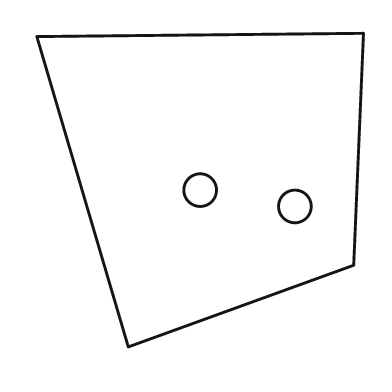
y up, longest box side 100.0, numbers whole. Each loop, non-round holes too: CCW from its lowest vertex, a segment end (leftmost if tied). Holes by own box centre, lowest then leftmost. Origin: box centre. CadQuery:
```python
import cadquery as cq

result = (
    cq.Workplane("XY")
    .moveTo(-22.0, -48.0)
    .lineTo(47.0, -23.0)
    .lineTo(50.0, 48.0)
    .lineTo(-50.0, 47.0)
    .close()
    .moveTo(29.0, -5.0)
    .circle(5.0)
    .moveTo(0.0, 0.0)
    .circle(5.0)
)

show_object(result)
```